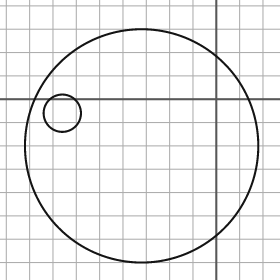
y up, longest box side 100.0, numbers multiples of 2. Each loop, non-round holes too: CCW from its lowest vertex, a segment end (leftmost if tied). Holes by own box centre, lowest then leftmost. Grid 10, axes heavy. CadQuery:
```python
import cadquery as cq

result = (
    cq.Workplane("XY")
    .moveTo(-32.0, -20.0)
    .circle(50.0)
    .moveTo(-66.0, -6.0)
    .circle(8.0)
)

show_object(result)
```